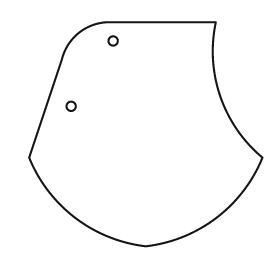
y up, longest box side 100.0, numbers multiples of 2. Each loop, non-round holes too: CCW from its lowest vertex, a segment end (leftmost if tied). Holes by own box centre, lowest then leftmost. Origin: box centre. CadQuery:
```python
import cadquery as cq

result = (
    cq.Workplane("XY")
    .moveTo(0.0, -48.0)
    .threePointArc((30.0, -36.0), (50.0, -10.0))
    .threePointArc((32.0, 16.0), (30.0, 48.0))
    .lineTo(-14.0, 48.0)
    .threePointArc((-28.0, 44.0), (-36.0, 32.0))
    .lineTo(-50.0, -10.0)
    .threePointArc((-30.0, -36.0), (0.0, -48.0))
    .close()
    .moveTo(-32.0, 12.0)
    .circle(2.0)
    .moveTo(-14.0, 40.0)
    .circle(2.0)
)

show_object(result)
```